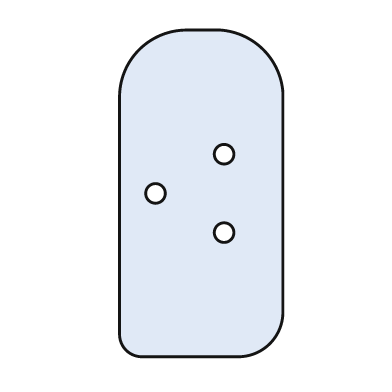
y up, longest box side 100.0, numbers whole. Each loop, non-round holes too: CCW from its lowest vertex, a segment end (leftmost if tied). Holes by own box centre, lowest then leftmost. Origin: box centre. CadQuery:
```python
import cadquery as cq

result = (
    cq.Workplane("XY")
    .moveTo(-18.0, -50.0)
    .lineTo(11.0, -50.0)
    .threePointArc((21.0, -46.0), (25.0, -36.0))
    .lineTo(25.0, 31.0)
    .threePointArc((19.0, 44.0), (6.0, 50.0))
    .lineTo(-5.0, 50.0)
    .threePointArc((-19.0, 44.0), (-25.0, 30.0))
    .lineTo(-25.0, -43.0)
    .threePointArc((-23.0, -48.0), (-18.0, -50.0))
    .close()
    .moveTo(7.0, -12.0)
    .circle(3.0)
    .moveTo(-14.0, 0.0)
    .circle(3.0)
    .moveTo(7.0, 12.0)
    .circle(3.0)
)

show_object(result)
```